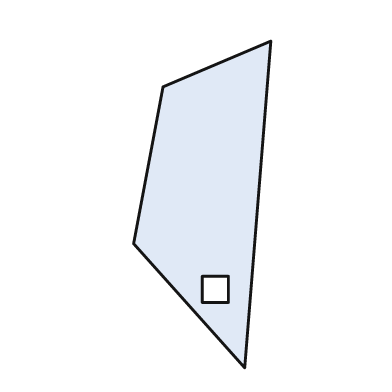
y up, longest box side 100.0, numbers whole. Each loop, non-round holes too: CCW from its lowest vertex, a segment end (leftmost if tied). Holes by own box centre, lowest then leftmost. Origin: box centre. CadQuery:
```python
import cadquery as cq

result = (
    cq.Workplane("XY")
    .moveTo(13.0, -50.0)
    .lineTo(21.0, 50.0)
    .lineTo(-12.0, 36.0)
    .lineTo(-21.0, -12.0)
    .close()
    .moveTo(0.0, -30.0)
    .lineTo(8.0, -30.0)
    .lineTo(8.0, -22.0)
    .lineTo(0.0, -22.0)
    .close()
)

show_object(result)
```